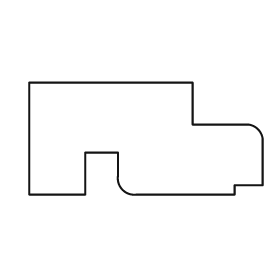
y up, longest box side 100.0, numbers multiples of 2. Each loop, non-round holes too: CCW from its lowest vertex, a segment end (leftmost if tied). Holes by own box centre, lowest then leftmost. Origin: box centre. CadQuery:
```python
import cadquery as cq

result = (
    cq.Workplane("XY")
    .moveTo(-50.0, -24.0)
    .lineTo(-26.0, -24.0)
    .lineTo(-26.0, -6.0)
    .lineTo(-12.0, -6.0)
    .lineTo(-12.0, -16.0)
    .threePointArc((-10.0, -22.0), (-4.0, -24.0))
    .lineTo(38.0, -24.0)
    .lineTo(38.0, -20.0)
    .lineTo(50.0, -20.0)
    .lineTo(50.0, 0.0)
    .threePointArc((48.0, 4.0), (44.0, 6.0))
    .lineTo(20.0, 6.0)
    .lineTo(20.0, 24.0)
    .lineTo(-50.0, 24.0)
    .close()
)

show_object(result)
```